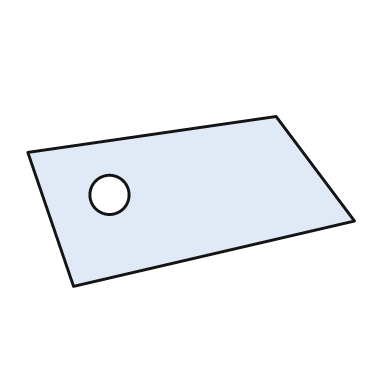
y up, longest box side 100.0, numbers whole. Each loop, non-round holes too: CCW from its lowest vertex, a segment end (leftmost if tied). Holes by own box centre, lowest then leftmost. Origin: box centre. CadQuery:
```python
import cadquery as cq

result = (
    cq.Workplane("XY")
    .moveTo(-36.0, -26.0)
    .lineTo(50.0, -6.0)
    .lineTo(26.0, 26.0)
    .lineTo(-50.0, 15.0)
    .close()
    .moveTo(-25.0, 2.0)
    .circle(6.0)
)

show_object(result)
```